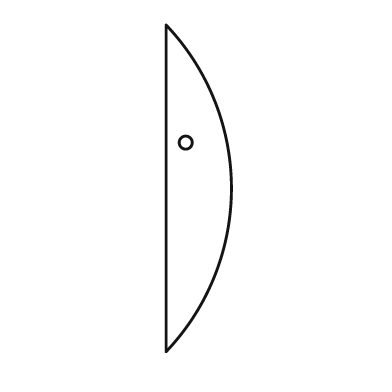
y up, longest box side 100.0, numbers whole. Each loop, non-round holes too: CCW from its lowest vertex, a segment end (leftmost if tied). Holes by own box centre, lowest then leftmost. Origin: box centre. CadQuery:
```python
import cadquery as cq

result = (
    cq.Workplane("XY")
    .moveTo(-10.0, -50.0)
    .threePointArc((10.0, 0.0), (-10.0, 50.0))
    .close()
    .moveTo(-4.0, 14.0)
    .circle(2.0)
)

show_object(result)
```